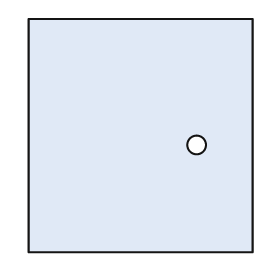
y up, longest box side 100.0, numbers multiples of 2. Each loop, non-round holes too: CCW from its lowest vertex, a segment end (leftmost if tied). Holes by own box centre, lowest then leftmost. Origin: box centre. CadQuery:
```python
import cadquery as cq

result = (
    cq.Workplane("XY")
    .moveTo(-48.0, -50.0)
    .lineTo(48.0, -50.0)
    .lineTo(48.0, 50.0)
    .lineTo(-48.0, 50.0)
    .close()
    .moveTo(24.0, -4.0)
    .circle(4.0)
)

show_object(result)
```